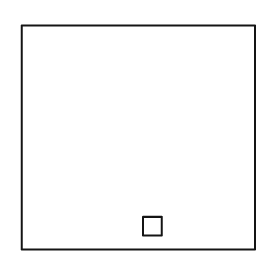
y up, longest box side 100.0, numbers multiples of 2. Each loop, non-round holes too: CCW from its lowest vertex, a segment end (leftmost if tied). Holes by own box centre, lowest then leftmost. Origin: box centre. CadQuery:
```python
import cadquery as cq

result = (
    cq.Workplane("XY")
    .moveTo(-50.0, -48.0)
    .lineTo(50.0, -48.0)
    .lineTo(50.0, 48.0)
    .lineTo(-50.0, 48.0)
    .close()
    .moveTo(2.0, -42.0)
    .lineTo(10.0, -42.0)
    .lineTo(10.0, -34.0)
    .lineTo(2.0, -34.0)
    .close()
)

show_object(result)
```